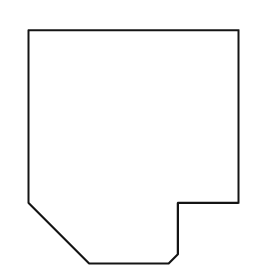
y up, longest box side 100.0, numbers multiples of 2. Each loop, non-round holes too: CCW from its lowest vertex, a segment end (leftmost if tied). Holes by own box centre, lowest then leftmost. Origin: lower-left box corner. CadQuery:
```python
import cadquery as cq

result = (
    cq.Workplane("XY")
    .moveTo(26.0, 0.0)
    .lineTo(60.0, 0.0)
    .lineTo(64.0, 4.0)
    .lineTo(64.0, 26.0)
    .lineTo(90.0, 26.0)
    .lineTo(90.0, 100.0)
    .lineTo(0.0, 100.0)
    .lineTo(0.0, 26.0)
    .close()
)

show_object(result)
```